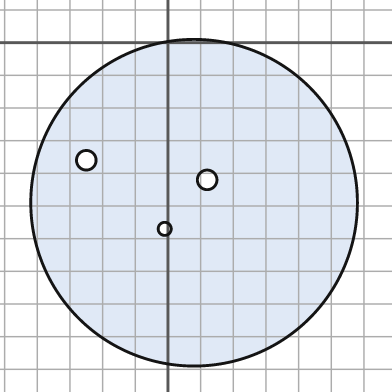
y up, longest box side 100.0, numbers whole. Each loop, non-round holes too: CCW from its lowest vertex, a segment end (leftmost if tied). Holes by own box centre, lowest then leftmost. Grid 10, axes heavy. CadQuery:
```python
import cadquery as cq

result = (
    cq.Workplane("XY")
    .moveTo(8.0, -49.0)
    .circle(50.0)
    .moveTo(-1.0, -57.0)
    .circle(2.0)
    .moveTo(12.0, -42.0)
    .circle(3.0)
    .moveTo(-25.0, -36.0)
    .circle(3.0)
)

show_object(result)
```